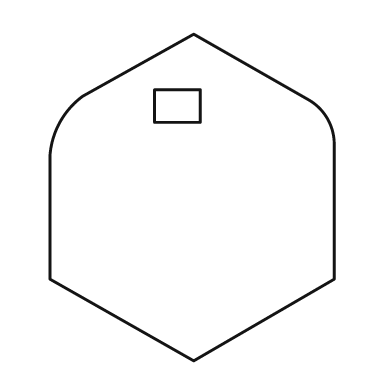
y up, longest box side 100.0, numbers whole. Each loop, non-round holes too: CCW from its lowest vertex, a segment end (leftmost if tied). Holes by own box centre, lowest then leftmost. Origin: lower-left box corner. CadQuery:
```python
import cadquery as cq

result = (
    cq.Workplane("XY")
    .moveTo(44.0, 0.0)
    .lineTo(87.0, 25.0)
    .lineTo(87.0, 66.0)
    .threePointArc((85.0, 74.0), (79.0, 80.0))
    .lineTo(44.0, 100.0)
    .lineTo(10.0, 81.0)
    .threePointArc((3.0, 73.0), (0.0, 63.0))
    .lineTo(0.0, 25.0)
    .close()
    .moveTo(32.0, 73.0)
    .lineTo(46.0, 73.0)
    .lineTo(46.0, 83.0)
    .lineTo(32.0, 83.0)
    .close()
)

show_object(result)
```